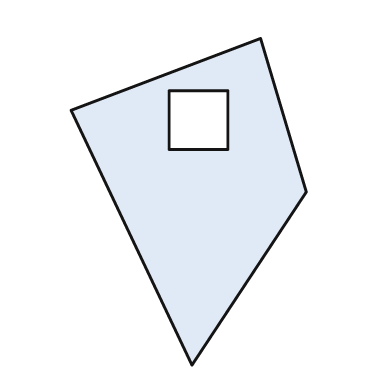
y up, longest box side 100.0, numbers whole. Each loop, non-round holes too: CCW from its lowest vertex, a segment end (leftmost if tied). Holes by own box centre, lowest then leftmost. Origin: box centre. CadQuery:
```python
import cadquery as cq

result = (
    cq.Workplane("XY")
    .moveTo(1.0, -50.0)
    .lineTo(36.0, 3.0)
    .lineTo(22.0, 50.0)
    .lineTo(-36.0, 28.0)
    .close()
    .moveTo(-6.0, 16.0)
    .lineTo(12.0, 16.0)
    .lineTo(12.0, 34.0)
    .lineTo(-6.0, 34.0)
    .close()
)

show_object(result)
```